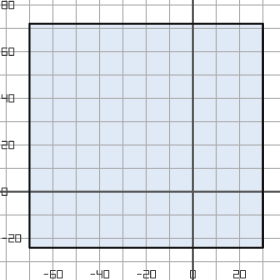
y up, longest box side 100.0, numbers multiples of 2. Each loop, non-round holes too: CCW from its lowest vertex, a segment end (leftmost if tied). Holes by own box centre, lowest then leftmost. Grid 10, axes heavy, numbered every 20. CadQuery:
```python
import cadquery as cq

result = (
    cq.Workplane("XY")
    .moveTo(-70.0, -24.0)
    .lineTo(30.0, -24.0)
    .lineTo(30.0, 72.0)
    .lineTo(-70.0, 72.0)
    .close()
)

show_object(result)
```